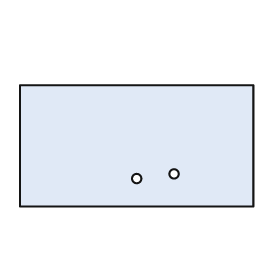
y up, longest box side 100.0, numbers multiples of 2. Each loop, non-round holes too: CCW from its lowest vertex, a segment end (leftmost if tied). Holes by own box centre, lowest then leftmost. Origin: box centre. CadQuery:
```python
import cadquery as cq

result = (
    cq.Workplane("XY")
    .moveTo(-50.0, -26.0)
    .lineTo(50.0, -26.0)
    .lineTo(50.0, 26.0)
    .lineTo(-50.0, 26.0)
    .close()
    .moveTo(0.0, -14.0)
    .circle(2.0)
    .moveTo(16.0, -12.0)
    .circle(2.0)
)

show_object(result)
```